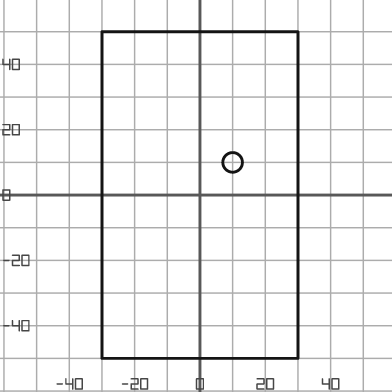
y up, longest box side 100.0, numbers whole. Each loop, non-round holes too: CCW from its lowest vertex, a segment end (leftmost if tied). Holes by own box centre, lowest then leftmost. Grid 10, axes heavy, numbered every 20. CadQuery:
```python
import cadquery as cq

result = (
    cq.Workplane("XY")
    .moveTo(-30.0, -50.0)
    .lineTo(30.0, -50.0)
    .lineTo(30.0, 50.0)
    .lineTo(-30.0, 50.0)
    .close()
    .moveTo(10.0, 10.0)
    .circle(3.0)
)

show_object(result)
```